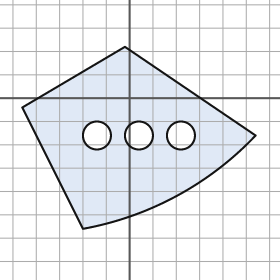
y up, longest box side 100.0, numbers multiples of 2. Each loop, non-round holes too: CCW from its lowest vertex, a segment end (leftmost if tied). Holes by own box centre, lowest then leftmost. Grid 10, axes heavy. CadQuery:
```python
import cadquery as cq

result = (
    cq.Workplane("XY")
    .moveTo(-20.0, -56.0)
    .threePointArc((20.0, -42.0), (54.0, -16.0))
    .lineTo(-2.0, 22.0)
    .lineTo(-46.0, -4.0)
    .close()
    .moveTo(-14.0, -16.0)
    .circle(6.0)
    .moveTo(4.0, -16.0)
    .circle(6.0)
    .moveTo(22.0, -16.0)
    .circle(6.0)
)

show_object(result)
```